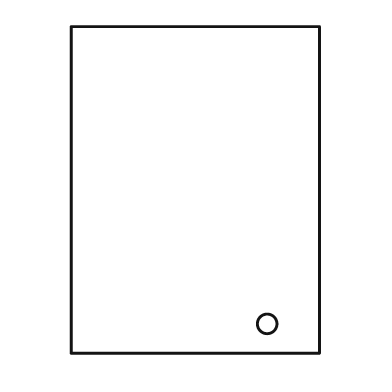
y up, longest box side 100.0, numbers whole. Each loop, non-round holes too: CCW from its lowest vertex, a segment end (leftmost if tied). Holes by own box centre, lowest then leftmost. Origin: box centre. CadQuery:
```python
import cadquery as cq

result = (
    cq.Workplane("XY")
    .moveTo(-38.0, -50.0)
    .lineTo(38.0, -50.0)
    .lineTo(38.0, 50.0)
    .lineTo(-38.0, 50.0)
    .close()
    .moveTo(22.0, -41.0)
    .circle(3.0)
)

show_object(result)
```